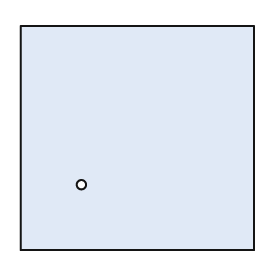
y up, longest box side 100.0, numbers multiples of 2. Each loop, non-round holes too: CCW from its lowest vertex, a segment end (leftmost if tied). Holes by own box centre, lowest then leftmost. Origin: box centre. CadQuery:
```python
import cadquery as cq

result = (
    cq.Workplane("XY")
    .moveTo(-50.0, -48.0)
    .lineTo(50.0, -48.0)
    .lineTo(50.0, 48.0)
    .lineTo(-50.0, 48.0)
    .close()
    .moveTo(-24.0, -20.0)
    .circle(2.0)
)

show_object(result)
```